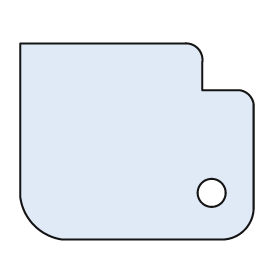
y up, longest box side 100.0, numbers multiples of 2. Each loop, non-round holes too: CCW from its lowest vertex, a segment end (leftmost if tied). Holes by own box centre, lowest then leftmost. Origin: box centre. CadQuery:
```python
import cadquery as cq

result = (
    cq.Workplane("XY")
    .moveTo(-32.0, -42.0)
    .lineTo(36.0, -42.0)
    .threePointArc((46.0, -38.0), (50.0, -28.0))
    .lineTo(50.0, 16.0)
    .threePointArc((48.0, 20.0), (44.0, 22.0))
    .lineTo(28.0, 22.0)
    .lineTo(28.0, 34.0)
    .threePointArc((26.0, 40.0), (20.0, 42.0))
    .lineTo(-50.0, 42.0)
    .lineTo(-50.0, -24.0)
    .threePointArc((-44.0, -36.0), (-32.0, -42.0))
    .close()
    .moveTo(32.0, -22.0)
    .circle(6.0)
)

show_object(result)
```